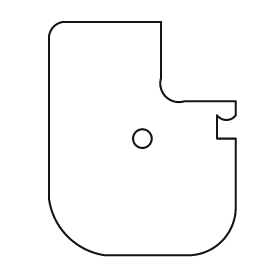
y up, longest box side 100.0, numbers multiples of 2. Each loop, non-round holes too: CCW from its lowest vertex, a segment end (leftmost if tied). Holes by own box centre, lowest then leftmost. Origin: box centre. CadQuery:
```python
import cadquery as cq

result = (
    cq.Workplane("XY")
    .moveTo(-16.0, -50.0)
    .lineTo(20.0, -50.0)
    .threePointArc((34.0, -44.0), (40.0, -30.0))
    .lineTo(40.0, 0.0)
    .lineTo(32.0, 0.0)
    .lineTo(32.0, 10.0)
    .threePointArc((36.0, 8.0), (40.0, 10.0))
    .lineTo(40.0, 16.0)
    .lineTo(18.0, 16.0)
    .threePointArc((10.0, 18.0), (8.0, 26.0))
    .lineTo(8.0, 50.0)
    .lineTo(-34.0, 50.0)
    .threePointArc((-38.0, 48.0), (-40.0, 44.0))
    .lineTo(-40.0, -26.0)
    .threePointArc((-32.0, -42.0), (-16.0, -50.0))
    .close()
    .moveTo(0.0, 0.0)
    .circle(4.0)
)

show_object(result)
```